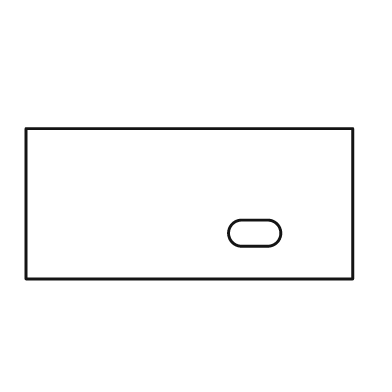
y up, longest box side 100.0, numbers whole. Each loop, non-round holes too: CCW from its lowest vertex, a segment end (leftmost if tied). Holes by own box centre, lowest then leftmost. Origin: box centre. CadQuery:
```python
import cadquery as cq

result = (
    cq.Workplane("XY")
    .moveTo(-50.0, -23.0)
    .lineTo(50.0, -23.0)
    .lineTo(50.0, 23.0)
    .lineTo(-50.0, 23.0)
    .close()
    .moveTo(16.0, -13.0)
    .lineTo(24.0, -13.0)
    .threePointArc((28.0, -9.0), (24.0, -5.0))
    .lineTo(16.0, -5.0)
    .threePointArc((12.0, -9.0), (16.0, -13.0))
    .close()
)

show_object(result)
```